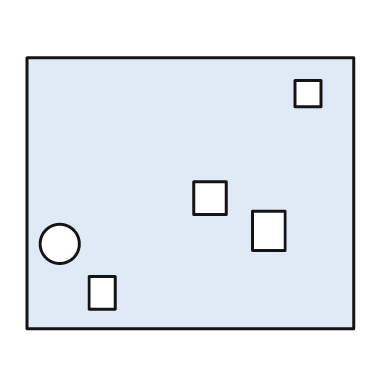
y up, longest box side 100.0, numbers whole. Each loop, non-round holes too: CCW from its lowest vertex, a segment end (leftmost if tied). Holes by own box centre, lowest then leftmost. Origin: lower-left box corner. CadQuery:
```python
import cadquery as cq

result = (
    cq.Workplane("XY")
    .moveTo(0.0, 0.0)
    .lineTo(100.0, 0.0)
    .lineTo(100.0, 83.0)
    .lineTo(0.0, 83.0)
    .close()
    .moveTo(19.0, 6.0)
    .lineTo(27.0, 6.0)
    .lineTo(27.0, 16.0)
    .lineTo(19.0, 16.0)
    .close()
    .moveTo(10.0, 26.0)
    .circle(6.0)
    .moveTo(69.0, 24.0)
    .lineTo(79.0, 24.0)
    .lineTo(79.0, 36.0)
    .lineTo(69.0, 36.0)
    .close()
    .moveTo(51.0, 35.0)
    .lineTo(61.0, 35.0)
    .lineTo(61.0, 45.0)
    .lineTo(51.0, 45.0)
    .close()
    .moveTo(82.0, 68.0)
    .lineTo(90.0, 68.0)
    .lineTo(90.0, 76.0)
    .lineTo(82.0, 76.0)
    .close()
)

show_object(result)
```